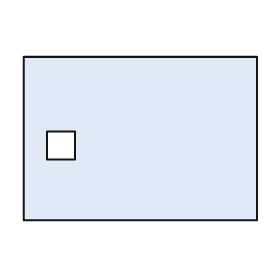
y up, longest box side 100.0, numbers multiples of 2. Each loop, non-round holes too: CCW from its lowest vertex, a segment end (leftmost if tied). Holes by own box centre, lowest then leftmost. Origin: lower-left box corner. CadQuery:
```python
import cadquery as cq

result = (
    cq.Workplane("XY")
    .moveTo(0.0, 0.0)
    .lineTo(100.0, 0.0)
    .lineTo(100.0, 70.0)
    .lineTo(0.0, 70.0)
    .close()
    .moveTo(10.0, 26.0)
    .lineTo(22.0, 26.0)
    .lineTo(22.0, 38.0)
    .lineTo(10.0, 38.0)
    .close()
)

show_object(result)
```